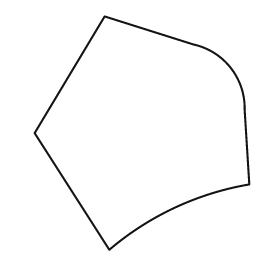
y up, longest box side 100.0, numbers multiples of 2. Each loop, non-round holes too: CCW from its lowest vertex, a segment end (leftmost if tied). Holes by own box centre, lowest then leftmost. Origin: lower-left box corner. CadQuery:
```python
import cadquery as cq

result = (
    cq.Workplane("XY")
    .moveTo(32.0, 0.0)
    .threePointArc((60.0, 18.0), (92.0, 28.0))
    .lineTo(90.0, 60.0)
    .threePointArc((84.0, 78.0), (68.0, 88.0))
    .lineTo(30.0, 100.0)
    .lineTo(0.0, 50.0)
    .close()
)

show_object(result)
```